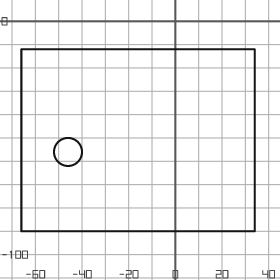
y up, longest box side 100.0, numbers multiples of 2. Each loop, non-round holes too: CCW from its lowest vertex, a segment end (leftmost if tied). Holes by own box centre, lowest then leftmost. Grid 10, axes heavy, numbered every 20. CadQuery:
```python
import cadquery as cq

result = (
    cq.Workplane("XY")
    .moveTo(-66.0, -90.0)
    .lineTo(34.0, -90.0)
    .lineTo(34.0, -12.0)
    .lineTo(-66.0, -12.0)
    .close()
    .moveTo(-46.0, -56.0)
    .circle(6.0)
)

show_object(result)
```